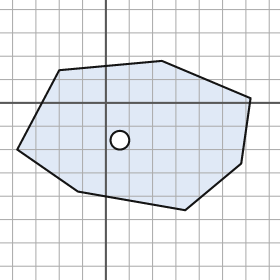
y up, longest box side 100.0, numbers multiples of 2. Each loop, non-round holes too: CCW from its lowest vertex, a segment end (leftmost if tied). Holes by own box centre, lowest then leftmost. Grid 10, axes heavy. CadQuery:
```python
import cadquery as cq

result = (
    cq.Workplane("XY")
    .moveTo(34.0, -46.0)
    .lineTo(58.0, -26.0)
    .lineTo(62.0, 2.0)
    .lineTo(24.0, 18.0)
    .lineTo(-20.0, 14.0)
    .lineTo(-38.0, -20.0)
    .lineTo(-12.0, -38.0)
    .close()
    .moveTo(6.0, -16.0)
    .circle(4.0)
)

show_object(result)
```